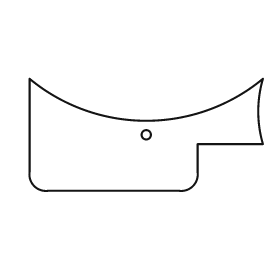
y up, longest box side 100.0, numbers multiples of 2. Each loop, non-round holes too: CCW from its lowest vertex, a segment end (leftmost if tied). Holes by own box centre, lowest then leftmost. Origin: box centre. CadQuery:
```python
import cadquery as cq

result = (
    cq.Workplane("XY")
    .moveTo(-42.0, -24.0)
    .lineTo(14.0, -24.0)
    .threePointArc((20.0, -22.0), (22.0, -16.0))
    .lineTo(22.0, -4.0)
    .lineTo(50.0, -4.0)
    .threePointArc((48.0, 10.0), (50.0, 24.0))
    .threePointArc((0.0, 6.0), (-50.0, 24.0))
    .lineTo(-50.0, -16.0)
    .threePointArc((-48.0, -22.0), (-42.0, -24.0))
    .close()
    .moveTo(0.0, 0.0)
    .circle(2.0)
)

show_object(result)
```